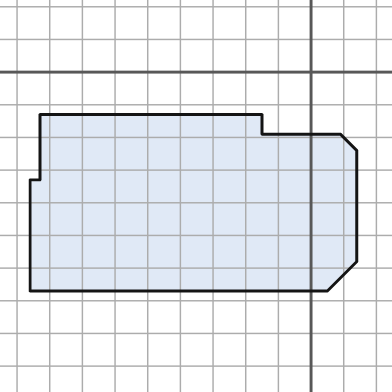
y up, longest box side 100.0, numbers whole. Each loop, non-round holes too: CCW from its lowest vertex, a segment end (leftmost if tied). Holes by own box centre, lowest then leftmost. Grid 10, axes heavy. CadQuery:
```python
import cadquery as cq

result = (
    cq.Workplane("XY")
    .moveTo(-86.0, -67.0)
    .lineTo(5.0, -67.0)
    .lineTo(14.0, -58.0)
    .lineTo(14.0, -24.0)
    .lineTo(9.0, -19.0)
    .lineTo(-15.0, -19.0)
    .lineTo(-15.0, -13.0)
    .lineTo(-83.0, -13.0)
    .lineTo(-83.0, -33.0)
    .lineTo(-86.0, -33.0)
    .close()
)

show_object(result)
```